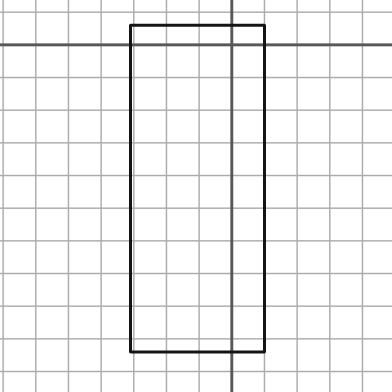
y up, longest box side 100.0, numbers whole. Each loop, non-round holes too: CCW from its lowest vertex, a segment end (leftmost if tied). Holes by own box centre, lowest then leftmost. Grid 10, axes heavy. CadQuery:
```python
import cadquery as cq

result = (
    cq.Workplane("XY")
    .moveTo(-31.0, -94.0)
    .lineTo(10.0, -94.0)
    .lineTo(10.0, 6.0)
    .lineTo(-31.0, 6.0)
    .close()
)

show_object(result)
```